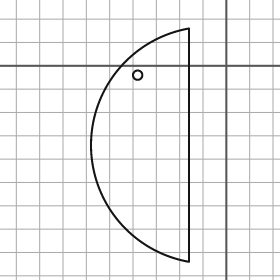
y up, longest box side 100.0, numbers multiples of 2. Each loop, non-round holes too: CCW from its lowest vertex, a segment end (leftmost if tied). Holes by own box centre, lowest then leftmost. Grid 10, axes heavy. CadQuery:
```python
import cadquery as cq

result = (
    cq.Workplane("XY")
    .moveTo(-16.0, -84.0)
    .lineTo(-16.0, 16.0)
    .threePointArc((-58.0, -34.0), (-16.0, -84.0))
    .close()
    .moveTo(-38.0, -4.0)
    .circle(2.0)
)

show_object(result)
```